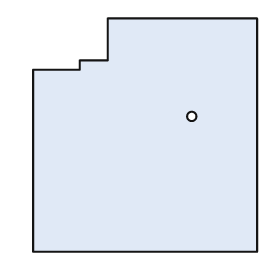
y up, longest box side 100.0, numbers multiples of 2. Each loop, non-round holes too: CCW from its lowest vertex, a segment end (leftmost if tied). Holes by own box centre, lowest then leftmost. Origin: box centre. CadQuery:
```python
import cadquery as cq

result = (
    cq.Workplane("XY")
    .moveTo(-48.0, -50.0)
    .lineTo(48.0, -50.0)
    .lineTo(48.0, 50.0)
    .lineTo(-16.0, 50.0)
    .lineTo(-16.0, 32.0)
    .lineTo(-28.0, 32.0)
    .lineTo(-28.0, 28.0)
    .lineTo(-48.0, 28.0)
    .close()
    .moveTo(20.0, 8.0)
    .circle(2.0)
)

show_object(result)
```